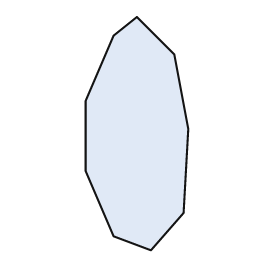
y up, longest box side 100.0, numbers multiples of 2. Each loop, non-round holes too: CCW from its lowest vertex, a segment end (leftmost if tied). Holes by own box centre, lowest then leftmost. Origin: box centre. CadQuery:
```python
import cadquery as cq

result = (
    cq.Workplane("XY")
    .moveTo(6.0, -50.0)
    .lineTo(20.0, -34.0)
    .lineTo(22.0, 2.0)
    .lineTo(16.0, 34.0)
    .lineTo(0.0, 50.0)
    .lineTo(-10.0, 42.0)
    .lineTo(-22.0, 14.0)
    .lineTo(-22.0, -16.0)
    .lineTo(-10.0, -44.0)
    .close()
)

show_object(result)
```